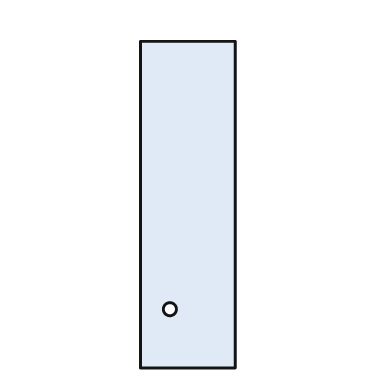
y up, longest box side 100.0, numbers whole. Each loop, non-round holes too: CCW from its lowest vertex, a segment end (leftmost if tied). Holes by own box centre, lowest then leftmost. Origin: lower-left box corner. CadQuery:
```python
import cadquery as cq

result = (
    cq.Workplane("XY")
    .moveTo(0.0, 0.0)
    .lineTo(29.0, 0.0)
    .lineTo(29.0, 100.0)
    .lineTo(0.0, 100.0)
    .close()
    .moveTo(9.0, 18.0)
    .circle(2.0)
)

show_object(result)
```